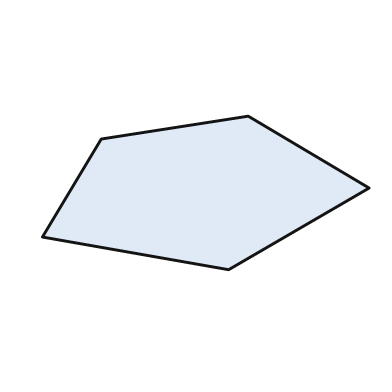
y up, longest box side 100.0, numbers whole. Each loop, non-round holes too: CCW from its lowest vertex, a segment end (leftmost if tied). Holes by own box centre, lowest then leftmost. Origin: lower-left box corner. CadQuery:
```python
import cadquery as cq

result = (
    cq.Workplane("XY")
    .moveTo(57.0, 0.0)
    .lineTo(100.0, 25.0)
    .lineTo(63.0, 47.0)
    .lineTo(18.0, 40.0)
    .lineTo(0.0, 10.0)
    .close()
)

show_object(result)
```